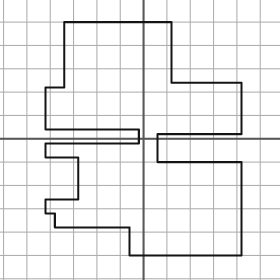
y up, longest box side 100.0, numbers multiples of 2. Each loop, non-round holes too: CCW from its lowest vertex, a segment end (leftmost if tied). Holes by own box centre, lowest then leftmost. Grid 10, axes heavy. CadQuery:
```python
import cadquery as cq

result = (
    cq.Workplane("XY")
    .moveTo(-6.0, -50.0)
    .lineTo(42.0, -50.0)
    .lineTo(42.0, -10.0)
    .lineTo(6.0, -10.0)
    .lineTo(6.0, 2.0)
    .lineTo(42.0, 2.0)
    .lineTo(42.0, 24.0)
    .lineTo(12.0, 24.0)
    .lineTo(12.0, 50.0)
    .lineTo(-34.0, 50.0)
    .lineTo(-34.0, 22.0)
    .lineTo(-42.0, 22.0)
    .lineTo(-42.0, 4.0)
    .lineTo(-2.0, 4.0)
    .lineTo(-2.0, -2.0)
    .lineTo(-42.0, -2.0)
    .lineTo(-42.0, -8.0)
    .lineTo(-28.0, -8.0)
    .lineTo(-28.0, -26.0)
    .lineTo(-42.0, -26.0)
    .lineTo(-42.0, -32.0)
    .lineTo(-38.0, -32.0)
    .lineTo(-38.0, -38.0)
    .lineTo(-6.0, -38.0)
    .close()
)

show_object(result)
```